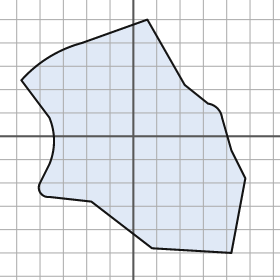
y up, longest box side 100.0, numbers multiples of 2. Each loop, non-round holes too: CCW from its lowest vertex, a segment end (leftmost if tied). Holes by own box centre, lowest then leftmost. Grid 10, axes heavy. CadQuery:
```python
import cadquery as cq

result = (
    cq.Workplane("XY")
    .moveTo(42.0, -50.0)
    .lineTo(48.0, -18.0)
    .lineTo(42.0, -6.0)
    .lineTo(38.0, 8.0)
    .threePointArc((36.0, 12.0), (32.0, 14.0))
    .lineTo(22.0, 22.0)
    .lineTo(6.0, 50.0)
    .lineTo(-22.0, 40.0)
    .threePointArc((-36.0, 34.0), (-48.0, 24.0))
    .lineTo(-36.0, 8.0)
    .threePointArc((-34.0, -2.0), (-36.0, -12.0))
    .lineTo(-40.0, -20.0)
    .threePointArc((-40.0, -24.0), (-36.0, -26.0))
    .lineTo(-18.0, -28.0)
    .lineTo(8.0, -48.0)
    .close()
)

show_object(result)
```